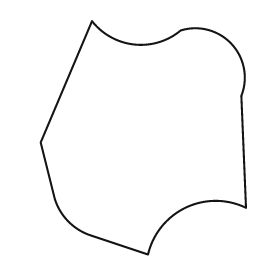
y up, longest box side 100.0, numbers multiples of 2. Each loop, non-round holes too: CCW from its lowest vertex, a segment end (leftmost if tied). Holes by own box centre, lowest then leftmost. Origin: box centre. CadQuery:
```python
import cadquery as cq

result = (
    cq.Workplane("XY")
    .moveTo(2.0, -50.0)
    .threePointArc((18.0, -30.0), (44.0, -30.0))
    .lineTo(42.0, 18.0)
    .threePointArc((38.0, 40.0), (16.0, 46.0))
    .threePointArc((-4.0, 40.0), (-22.0, 50.0))
    .lineTo(-44.0, -2.0)
    .lineTo(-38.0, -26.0)
    .threePointArc((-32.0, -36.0), (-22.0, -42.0))
    .close()
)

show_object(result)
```